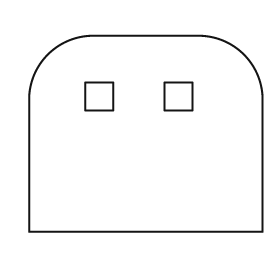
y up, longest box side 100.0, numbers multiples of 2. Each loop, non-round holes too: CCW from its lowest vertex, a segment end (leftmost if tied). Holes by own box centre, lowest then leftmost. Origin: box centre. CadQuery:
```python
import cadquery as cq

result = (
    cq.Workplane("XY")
    .moveTo(-50.0, -42.0)
    .lineTo(50.0, -42.0)
    .lineTo(50.0, 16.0)
    .threePointArc((42.0, 34.0), (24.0, 42.0))
    .lineTo(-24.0, 42.0)
    .threePointArc((-42.0, 34.0), (-50.0, 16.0))
    .close()
    .moveTo(-26.0, 10.0)
    .lineTo(-14.0, 10.0)
    .lineTo(-14.0, 22.0)
    .lineTo(-26.0, 22.0)
    .close()
    .moveTo(8.0, 10.0)
    .lineTo(20.0, 10.0)
    .lineTo(20.0, 22.0)
    .lineTo(8.0, 22.0)
    .close()
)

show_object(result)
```